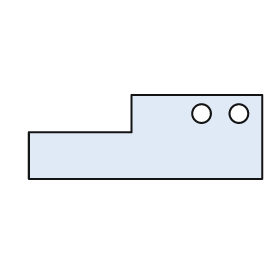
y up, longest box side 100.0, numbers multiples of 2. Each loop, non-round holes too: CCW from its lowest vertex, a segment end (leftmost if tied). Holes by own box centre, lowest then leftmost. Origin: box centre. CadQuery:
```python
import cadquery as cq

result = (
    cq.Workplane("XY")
    .moveTo(-50.0, -18.0)
    .lineTo(50.0, -18.0)
    .lineTo(50.0, 18.0)
    .lineTo(-6.0, 18.0)
    .lineTo(-6.0, 2.0)
    .lineTo(-50.0, 2.0)
    .close()
    .moveTo(24.0, 10.0)
    .circle(4.0)
    .moveTo(40.0, 10.0)
    .circle(4.0)
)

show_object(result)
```